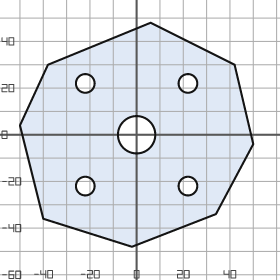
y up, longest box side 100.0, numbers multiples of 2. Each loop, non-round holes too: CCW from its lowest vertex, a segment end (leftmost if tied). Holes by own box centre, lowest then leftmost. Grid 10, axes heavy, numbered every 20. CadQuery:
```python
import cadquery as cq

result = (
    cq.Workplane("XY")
    .moveTo(-2.0, -48.0)
    .lineTo(34.0, -34.0)
    .lineTo(50.0, -4.0)
    .lineTo(42.0, 30.0)
    .lineTo(6.0, 48.0)
    .lineTo(-38.0, 30.0)
    .lineTo(-50.0, 4.0)
    .lineTo(-40.0, -36.0)
    .close()
    .moveTo(-22.0, -22.0)
    .circle(4.0)
    .moveTo(22.0, -22.0)
    .circle(4.0)
    .moveTo(0.0, 0.0)
    .circle(8.0)
    .moveTo(-22.0, 22.0)
    .circle(4.0)
    .moveTo(22.0, 22.0)
    .circle(4.0)
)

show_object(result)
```